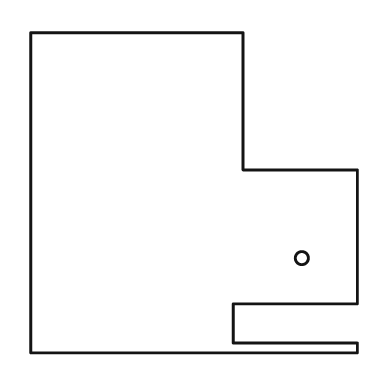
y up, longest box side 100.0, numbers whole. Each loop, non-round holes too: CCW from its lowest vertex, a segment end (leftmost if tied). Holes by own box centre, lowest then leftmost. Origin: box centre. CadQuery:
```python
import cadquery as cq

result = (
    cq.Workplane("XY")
    .moveTo(-50.0, -49.0)
    .lineTo(50.0, -49.0)
    .lineTo(50.0, -46.0)
    .lineTo(12.0, -46.0)
    .lineTo(12.0, -34.0)
    .lineTo(50.0, -34.0)
    .lineTo(50.0, 7.0)
    .lineTo(15.0, 7.0)
    .lineTo(15.0, 49.0)
    .lineTo(-50.0, 49.0)
    .close()
    .moveTo(33.0, -20.0)
    .circle(2.0)
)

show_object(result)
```